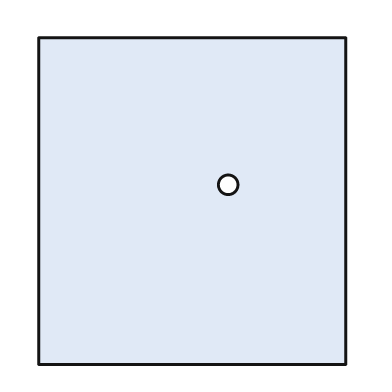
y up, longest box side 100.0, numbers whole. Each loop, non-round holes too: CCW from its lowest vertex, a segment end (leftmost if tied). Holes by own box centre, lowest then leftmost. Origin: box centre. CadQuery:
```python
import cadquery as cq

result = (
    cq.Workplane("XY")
    .moveTo(-47.0, -50.0)
    .lineTo(47.0, -50.0)
    .lineTo(47.0, 50.0)
    .lineTo(-47.0, 50.0)
    .close()
    .moveTo(11.0, 5.0)
    .circle(3.0)
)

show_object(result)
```